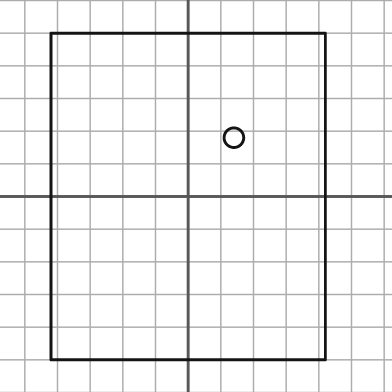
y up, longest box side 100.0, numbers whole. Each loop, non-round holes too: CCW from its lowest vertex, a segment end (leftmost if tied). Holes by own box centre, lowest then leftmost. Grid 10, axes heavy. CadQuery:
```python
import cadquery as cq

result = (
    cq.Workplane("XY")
    .moveTo(-42.0, -50.0)
    .lineTo(42.0, -50.0)
    .lineTo(42.0, 50.0)
    .lineTo(-42.0, 50.0)
    .close()
    .moveTo(14.0, 18.0)
    .circle(3.0)
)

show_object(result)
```